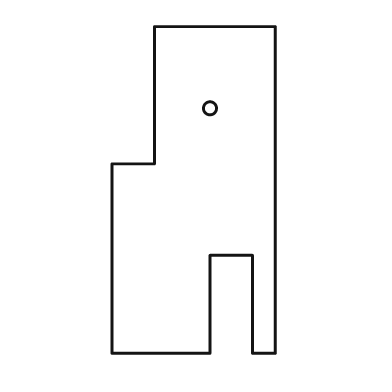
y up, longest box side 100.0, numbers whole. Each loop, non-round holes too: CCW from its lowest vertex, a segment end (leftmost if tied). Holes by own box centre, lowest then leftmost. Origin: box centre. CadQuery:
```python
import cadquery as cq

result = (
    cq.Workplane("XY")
    .moveTo(-25.0, -50.0)
    .lineTo(5.0, -50.0)
    .lineTo(5.0, -20.0)
    .lineTo(18.0, -20.0)
    .lineTo(18.0, -50.0)
    .lineTo(25.0, -50.0)
    .lineTo(25.0, 50.0)
    .lineTo(-12.0, 50.0)
    .lineTo(-12.0, 8.0)
    .lineTo(-25.0, 8.0)
    .close()
    .moveTo(5.0, 25.0)
    .circle(2.0)
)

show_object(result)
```